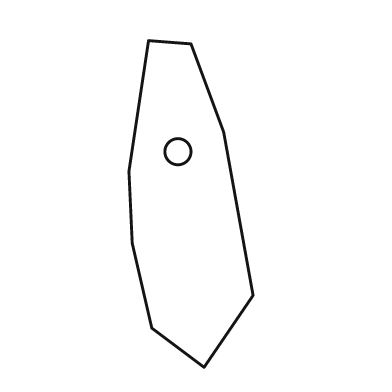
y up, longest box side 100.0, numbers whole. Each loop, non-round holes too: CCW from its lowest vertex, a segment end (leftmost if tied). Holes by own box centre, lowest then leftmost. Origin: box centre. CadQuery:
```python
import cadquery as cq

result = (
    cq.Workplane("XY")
    .moveTo(4.0, -50.0)
    .lineTo(19.0, -28.0)
    .lineTo(10.0, 22.0)
    .lineTo(0.0, 49.0)
    .lineTo(-13.0, 50.0)
    .lineTo(-19.0, 10.0)
    .lineTo(-18.0, -12.0)
    .lineTo(-12.0, -38.0)
    .close()
    .moveTo(-4.0, 16.0)
    .circle(4.0)
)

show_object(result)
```